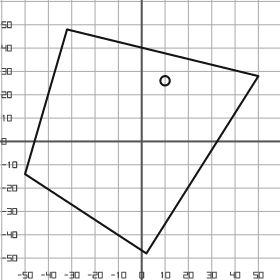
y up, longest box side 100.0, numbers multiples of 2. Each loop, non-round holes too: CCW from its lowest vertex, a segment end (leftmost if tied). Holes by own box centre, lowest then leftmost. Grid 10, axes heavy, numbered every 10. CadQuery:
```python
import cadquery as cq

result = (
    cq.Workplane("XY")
    .moveTo(2.0, -48.0)
    .lineTo(50.0, 28.0)
    .lineTo(-32.0, 48.0)
    .lineTo(-50.0, -14.0)
    .close()
    .moveTo(10.0, 26.0)
    .circle(2.0)
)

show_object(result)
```